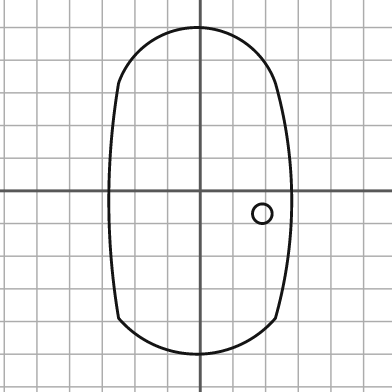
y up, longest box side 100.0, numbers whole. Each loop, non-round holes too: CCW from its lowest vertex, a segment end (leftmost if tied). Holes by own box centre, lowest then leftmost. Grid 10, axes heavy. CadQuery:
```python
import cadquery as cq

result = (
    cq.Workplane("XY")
    .moveTo(-25.0, -39.0)
    .threePointArc((-1.0, -50.0), (23.0, -39.0))
    .threePointArc((28.0, -3.0), (23.0, 33.0))
    .threePointArc((-1.0, 50.0), (-25.0, 33.0))
    .threePointArc((-28.0, -3.0), (-25.0, -39.0))
    .close()
    .moveTo(19.0, -7.0)
    .circle(3.0)
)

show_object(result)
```